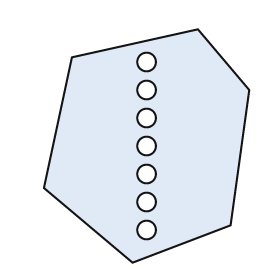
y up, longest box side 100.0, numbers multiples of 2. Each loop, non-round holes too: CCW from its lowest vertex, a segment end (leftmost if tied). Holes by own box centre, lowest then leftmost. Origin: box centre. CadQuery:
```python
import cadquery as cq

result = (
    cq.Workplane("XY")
    .moveTo(-6.0, -50.0)
    .lineTo(36.0, -34.0)
    .lineTo(44.0, 24.0)
    .lineTo(22.0, 50.0)
    .lineTo(-32.0, 38.0)
    .lineTo(-44.0, -18.0)
    .close()
    .moveTo(0.0, -36.0)
    .circle(4.0)
    .moveTo(0.0, -24.0)
    .circle(4.0)
    .moveTo(0.0, -12.0)
    .circle(4.0)
    .moveTo(0.0, 0.0)
    .circle(4.0)
    .moveTo(0.0, 12.0)
    .circle(4.0)
    .moveTo(0.0, 24.0)
    .circle(4.0)
    .moveTo(0.0, 36.0)
    .circle(4.0)
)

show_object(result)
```